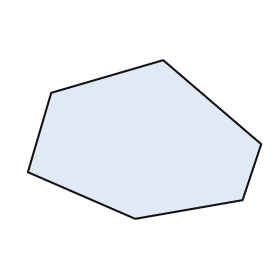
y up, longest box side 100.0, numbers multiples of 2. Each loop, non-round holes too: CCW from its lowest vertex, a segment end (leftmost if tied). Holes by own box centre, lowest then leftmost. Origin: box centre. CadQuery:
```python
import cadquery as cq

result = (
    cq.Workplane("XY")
    .moveTo(-4.0, -34.0)
    .lineTo(42.0, -26.0)
    .lineTo(50.0, -2.0)
    .lineTo(8.0, 34.0)
    .lineTo(-40.0, 20.0)
    .lineTo(-50.0, -14.0)
    .close()
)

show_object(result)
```